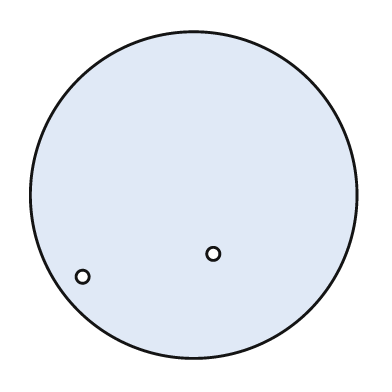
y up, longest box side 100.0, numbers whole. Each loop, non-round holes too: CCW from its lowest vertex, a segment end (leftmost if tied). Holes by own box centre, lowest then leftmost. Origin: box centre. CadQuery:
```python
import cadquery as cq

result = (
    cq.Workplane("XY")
    .moveTo(0.0, 0.0)
    .circle(50.0)
    .moveTo(-34.0, -25.0)
    .circle(2.0)
    .moveTo(6.0, -18.0)
    .circle(2.0)
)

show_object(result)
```